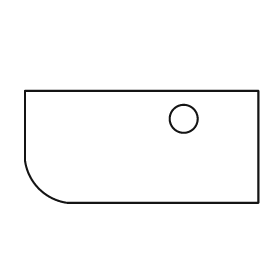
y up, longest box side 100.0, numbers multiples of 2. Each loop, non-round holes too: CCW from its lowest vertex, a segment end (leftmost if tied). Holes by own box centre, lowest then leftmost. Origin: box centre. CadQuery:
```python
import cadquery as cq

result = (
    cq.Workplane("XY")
    .moveTo(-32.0, -24.0)
    .lineTo(50.0, -24.0)
    .lineTo(50.0, 24.0)
    .lineTo(-50.0, 24.0)
    .lineTo(-50.0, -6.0)
    .threePointArc((-44.0, -18.0), (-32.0, -24.0))
    .close()
    .moveTo(18.0, 12.0)
    .circle(6.0)
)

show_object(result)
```